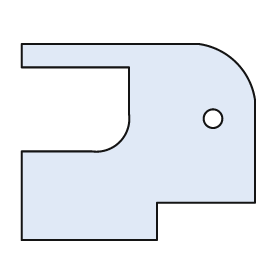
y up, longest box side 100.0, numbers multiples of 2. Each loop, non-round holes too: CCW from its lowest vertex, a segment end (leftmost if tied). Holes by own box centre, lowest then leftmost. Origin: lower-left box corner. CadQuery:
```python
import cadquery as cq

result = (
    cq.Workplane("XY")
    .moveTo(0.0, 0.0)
    .lineTo(58.0, 0.0)
    .lineTo(58.0, 16.0)
    .lineTo(100.0, 16.0)
    .lineTo(100.0, 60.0)
    .threePointArc((92.0, 76.0), (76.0, 84.0))
    .lineTo(0.0, 84.0)
    .lineTo(0.0, 74.0)
    .lineTo(46.0, 74.0)
    .lineTo(46.0, 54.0)
    .threePointArc((42.0, 42.0), (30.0, 38.0))
    .lineTo(0.0, 38.0)
    .close()
    .moveTo(82.0, 52.0)
    .circle(4.0)
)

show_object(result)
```